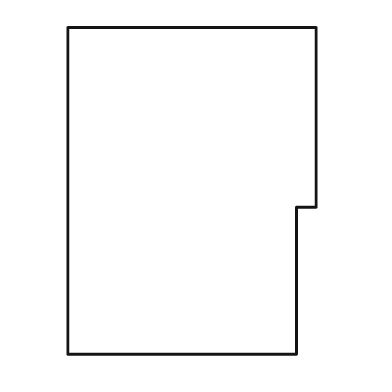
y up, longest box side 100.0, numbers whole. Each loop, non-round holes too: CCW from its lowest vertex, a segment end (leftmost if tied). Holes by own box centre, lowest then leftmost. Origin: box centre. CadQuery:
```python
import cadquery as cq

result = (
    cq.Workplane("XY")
    .moveTo(-38.0, -50.0)
    .lineTo(32.0, -50.0)
    .lineTo(32.0, -5.0)
    .lineTo(38.0, -5.0)
    .lineTo(38.0, 50.0)
    .lineTo(-38.0, 50.0)
    .close()
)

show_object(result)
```